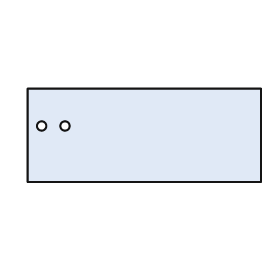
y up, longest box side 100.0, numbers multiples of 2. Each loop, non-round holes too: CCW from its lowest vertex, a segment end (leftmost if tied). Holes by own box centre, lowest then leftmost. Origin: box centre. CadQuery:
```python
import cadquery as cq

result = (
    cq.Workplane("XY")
    .moveTo(-50.0, -20.0)
    .lineTo(50.0, -20.0)
    .lineTo(50.0, 20.0)
    .lineTo(-50.0, 20.0)
    .close()
    .moveTo(-44.0, 4.0)
    .circle(2.0)
    .moveTo(-34.0, 4.0)
    .circle(2.0)
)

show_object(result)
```